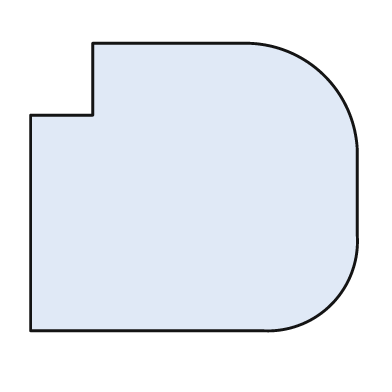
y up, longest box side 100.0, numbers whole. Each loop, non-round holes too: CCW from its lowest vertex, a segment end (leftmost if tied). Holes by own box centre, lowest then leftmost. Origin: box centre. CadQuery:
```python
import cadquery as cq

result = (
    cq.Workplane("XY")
    .moveTo(-50.0, -44.0)
    .lineTo(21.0, -44.0)
    .threePointArc((42.0, -36.0), (50.0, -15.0))
    .lineTo(50.0, 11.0)
    .threePointArc((40.0, 34.0), (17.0, 44.0))
    .lineTo(-31.0, 44.0)
    .lineTo(-31.0, 22.0)
    .lineTo(-50.0, 22.0)
    .close()
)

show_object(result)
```